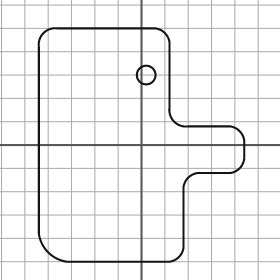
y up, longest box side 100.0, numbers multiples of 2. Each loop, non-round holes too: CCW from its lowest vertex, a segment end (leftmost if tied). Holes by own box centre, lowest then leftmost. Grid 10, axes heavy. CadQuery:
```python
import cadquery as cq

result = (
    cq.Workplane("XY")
    .moveTo(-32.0, -50.0)
    .lineTo(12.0, -50.0)
    .threePointArc((16.0, -48.0), (18.0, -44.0))
    .lineTo(18.0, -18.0)
    .threePointArc((20.0, -14.0), (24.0, -12.0))
    .lineTo(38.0, -12.0)
    .threePointArc((42.0, -10.0), (44.0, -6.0))
    .lineTo(44.0, 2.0)
    .threePointArc((42.0, 6.0), (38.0, 8.0))
    .lineTo(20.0, 8.0)
    .threePointArc((14.0, 10.0), (12.0, 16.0))
    .lineTo(12.0, 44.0)
    .threePointArc((10.0, 48.0), (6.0, 50.0))
    .lineTo(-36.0, 50.0)
    .threePointArc((-42.0, 48.0), (-44.0, 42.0))
    .lineTo(-44.0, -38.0)
    .threePointArc((-40.0, -46.0), (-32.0, -50.0))
    .close()
    .moveTo(2.0, 30.0)
    .circle(4.0)
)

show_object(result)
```